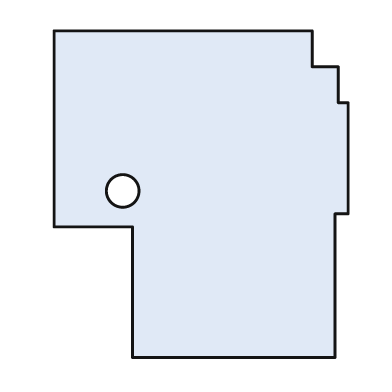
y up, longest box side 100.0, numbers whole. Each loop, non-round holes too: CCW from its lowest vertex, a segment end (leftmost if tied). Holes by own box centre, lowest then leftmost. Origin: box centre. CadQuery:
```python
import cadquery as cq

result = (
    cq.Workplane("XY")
    .moveTo(-21.0, -50.0)
    .lineTo(41.0, -50.0)
    .lineTo(41.0, -6.0)
    .lineTo(45.0, -6.0)
    .lineTo(45.0, 28.0)
    .lineTo(42.0, 28.0)
    .lineTo(42.0, 39.0)
    .lineTo(34.0, 39.0)
    .lineTo(34.0, 50.0)
    .lineTo(-45.0, 50.0)
    .lineTo(-45.0, -10.0)
    .lineTo(-21.0, -10.0)
    .close()
    .moveTo(-24.0, 1.0)
    .circle(5.0)
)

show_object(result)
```